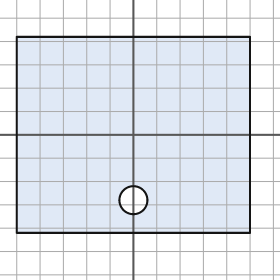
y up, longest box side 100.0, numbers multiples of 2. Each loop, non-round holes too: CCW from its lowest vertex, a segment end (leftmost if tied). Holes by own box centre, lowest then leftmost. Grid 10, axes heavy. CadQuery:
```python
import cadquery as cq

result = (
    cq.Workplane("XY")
    .moveTo(-50.0, -42.0)
    .lineTo(50.0, -42.0)
    .lineTo(50.0, 42.0)
    .lineTo(-50.0, 42.0)
    .close()
    .moveTo(0.0, -28.0)
    .circle(6.0)
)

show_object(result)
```